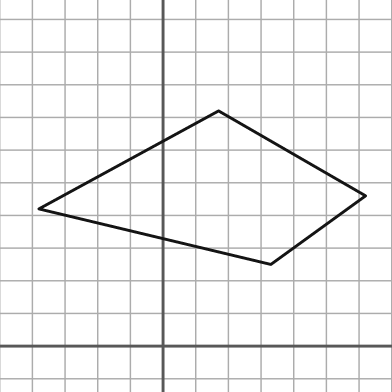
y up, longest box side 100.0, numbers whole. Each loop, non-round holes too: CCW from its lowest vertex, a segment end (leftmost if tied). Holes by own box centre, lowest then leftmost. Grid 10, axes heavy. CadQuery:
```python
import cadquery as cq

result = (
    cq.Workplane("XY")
    .moveTo(33.0, 25.0)
    .lineTo(62.0, 46.0)
    .lineTo(17.0, 72.0)
    .lineTo(-38.0, 42.0)
    .close()
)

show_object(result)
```